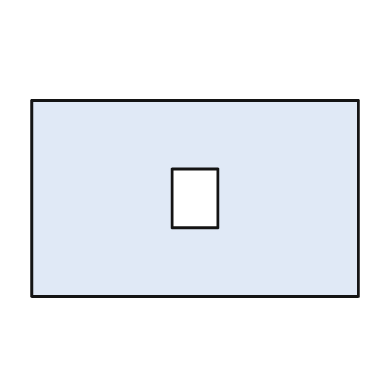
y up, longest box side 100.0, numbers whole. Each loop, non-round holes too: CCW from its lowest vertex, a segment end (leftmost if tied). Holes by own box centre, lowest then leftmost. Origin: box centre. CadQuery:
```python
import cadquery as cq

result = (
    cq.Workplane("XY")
    .moveTo(-50.0, -30.0)
    .lineTo(50.0, -30.0)
    .lineTo(50.0, 30.0)
    .lineTo(-50.0, 30.0)
    .close()
    .moveTo(-7.0, -9.0)
    .lineTo(7.0, -9.0)
    .lineTo(7.0, 9.0)
    .lineTo(-7.0, 9.0)
    .close()
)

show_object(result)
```